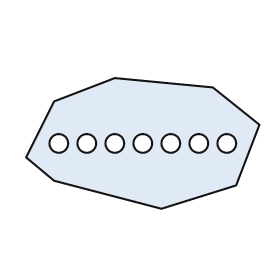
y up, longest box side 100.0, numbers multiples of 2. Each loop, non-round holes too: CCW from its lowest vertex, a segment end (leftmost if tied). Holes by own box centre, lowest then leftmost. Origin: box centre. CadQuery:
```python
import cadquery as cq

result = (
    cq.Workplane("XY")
    .moveTo(8.0, -28.0)
    .lineTo(40.0, -18.0)
    .lineTo(50.0, 8.0)
    .lineTo(30.0, 24.0)
    .lineTo(-12.0, 28.0)
    .lineTo(-38.0, 18.0)
    .lineTo(-50.0, -6.0)
    .lineTo(-38.0, -16.0)
    .close()
    .moveTo(-36.0, 0.0)
    .circle(4.0)
    .moveTo(-24.0, 0.0)
    .circle(4.0)
    .moveTo(-12.0, 0.0)
    .circle(4.0)
    .moveTo(0.0, 0.0)
    .circle(4.0)
    .moveTo(12.0, 0.0)
    .circle(4.0)
    .moveTo(24.0, 0.0)
    .circle(4.0)
    .moveTo(36.0, 0.0)
    .circle(4.0)
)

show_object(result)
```